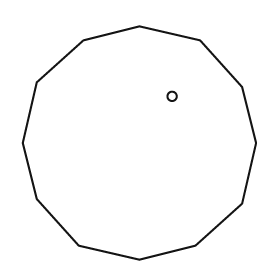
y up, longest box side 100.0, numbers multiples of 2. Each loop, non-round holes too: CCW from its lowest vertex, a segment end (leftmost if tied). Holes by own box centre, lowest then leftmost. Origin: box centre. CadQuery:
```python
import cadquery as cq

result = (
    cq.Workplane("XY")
    .moveTo(0.0, -50.0)
    .lineTo(24.0, -44.0)
    .lineTo(44.0, -26.0)
    .lineTo(50.0, 0.0)
    .lineTo(44.0, 24.0)
    .lineTo(26.0, 44.0)
    .lineTo(0.0, 50.0)
    .lineTo(-24.0, 44.0)
    .lineTo(-44.0, 26.0)
    .lineTo(-50.0, 0.0)
    .lineTo(-44.0, -24.0)
    .lineTo(-26.0, -44.0)
    .close()
    .moveTo(14.0, 20.0)
    .circle(2.0)
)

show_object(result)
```